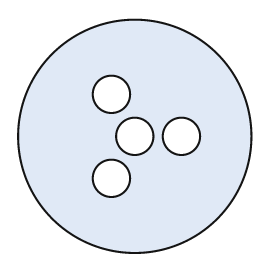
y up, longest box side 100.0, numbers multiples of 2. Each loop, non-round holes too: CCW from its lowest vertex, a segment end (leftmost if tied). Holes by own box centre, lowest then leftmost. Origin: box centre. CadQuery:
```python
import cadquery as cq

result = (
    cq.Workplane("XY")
    .moveTo(0.0, 0.0)
    .circle(50.0)
    .moveTo(-10.0, -18.0)
    .circle(8.0)
    .moveTo(0.0, 0.0)
    .circle(8.0)
    .moveTo(20.0, 0.0)
    .circle(8.0)
    .moveTo(-10.0, 18.0)
    .circle(8.0)
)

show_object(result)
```